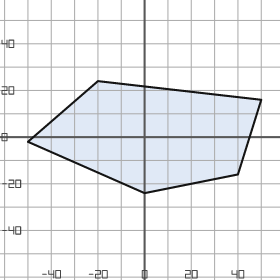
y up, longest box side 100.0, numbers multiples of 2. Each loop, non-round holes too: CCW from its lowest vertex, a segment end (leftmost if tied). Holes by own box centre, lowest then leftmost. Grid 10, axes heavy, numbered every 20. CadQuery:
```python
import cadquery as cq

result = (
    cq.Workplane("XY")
    .moveTo(0.0, -24.0)
    .lineTo(40.0, -16.0)
    .lineTo(50.0, 16.0)
    .lineTo(-20.0, 24.0)
    .lineTo(-50.0, -2.0)
    .close()
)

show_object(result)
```